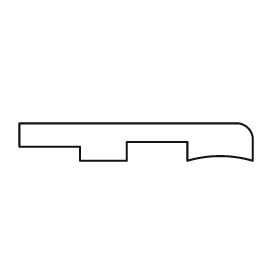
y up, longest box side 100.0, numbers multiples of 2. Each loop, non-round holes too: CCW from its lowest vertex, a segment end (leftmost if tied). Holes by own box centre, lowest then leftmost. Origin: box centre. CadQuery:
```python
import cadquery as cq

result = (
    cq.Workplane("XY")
    .moveTo(-24.0, -8.0)
    .lineTo(-4.0, -8.0)
    .lineTo(-4.0, 0.0)
    .lineTo(22.0, 0.0)
    .lineTo(22.0, -8.0)
    .threePointArc((36.0, -6.0), (50.0, -8.0))
    .lineTo(50.0, 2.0)
    .threePointArc((48.0, 6.0), (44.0, 8.0))
    .lineTo(-50.0, 8.0)
    .lineTo(-50.0, -2.0)
    .lineTo(-24.0, -2.0)
    .close()
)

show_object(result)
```